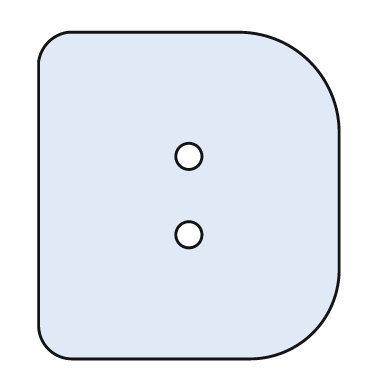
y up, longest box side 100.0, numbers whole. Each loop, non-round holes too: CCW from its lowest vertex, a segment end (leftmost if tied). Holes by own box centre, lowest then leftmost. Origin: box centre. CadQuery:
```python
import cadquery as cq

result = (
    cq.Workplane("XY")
    .moveTo(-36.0, -50.0)
    .lineTo(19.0, -50.0)
    .threePointArc((38.0, -42.0), (46.0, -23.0))
    .lineTo(46.0, 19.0)
    .threePointArc((37.0, 41.0), (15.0, 50.0))
    .lineTo(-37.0, 50.0)
    .threePointArc((-43.0, 47.0), (-46.0, 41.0))
    .lineTo(-46.0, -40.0)
    .threePointArc((-43.0, -47.0), (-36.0, -50.0))
    .close()
    .moveTo(0.0, -12.0)
    .circle(4.0)
    .moveTo(0.0, 12.0)
    .circle(4.0)
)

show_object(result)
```